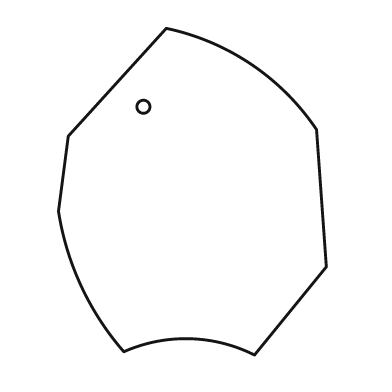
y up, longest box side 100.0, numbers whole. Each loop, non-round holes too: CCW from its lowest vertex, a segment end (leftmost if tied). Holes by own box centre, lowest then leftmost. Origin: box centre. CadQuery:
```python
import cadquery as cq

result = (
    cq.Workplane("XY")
    .moveTo(19.0, -50.0)
    .lineTo(41.0, -23.0)
    .lineTo(38.0, 19.0)
    .threePointArc((18.0, 39.0), (-8.0, 50.0))
    .lineTo(-38.0, 17.0)
    .lineTo(-41.0, -6.0)
    .threePointArc((-34.0, -29.0), (-21.0, -49.0))
    .threePointArc((-1.0, -45.0), (19.0, -50.0))
    .close()
    .moveTo(-15.0, 26.0)
    .circle(2.0)
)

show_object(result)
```